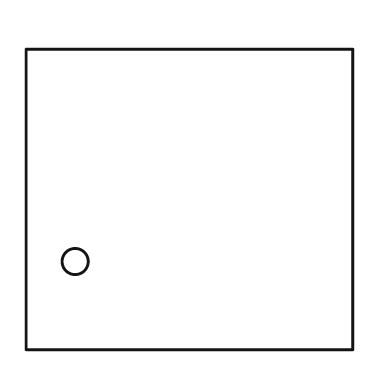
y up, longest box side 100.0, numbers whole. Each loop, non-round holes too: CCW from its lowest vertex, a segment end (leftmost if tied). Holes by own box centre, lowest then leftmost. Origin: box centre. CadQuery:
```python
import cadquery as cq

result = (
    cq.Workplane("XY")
    .moveTo(-50.0, -46.0)
    .lineTo(50.0, -46.0)
    .lineTo(50.0, 46.0)
    .lineTo(-50.0, 46.0)
    .close()
    .moveTo(-35.0, -19.0)
    .circle(4.0)
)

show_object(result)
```